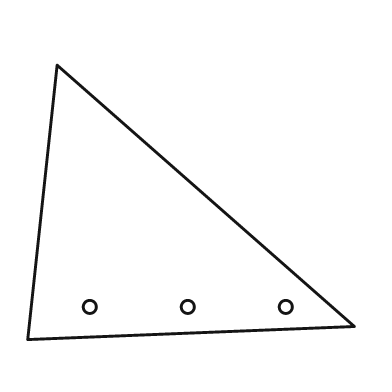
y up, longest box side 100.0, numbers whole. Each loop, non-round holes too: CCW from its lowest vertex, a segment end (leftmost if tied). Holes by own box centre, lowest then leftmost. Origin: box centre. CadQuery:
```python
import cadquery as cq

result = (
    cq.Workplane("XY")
    .moveTo(-50.0, -42.0)
    .lineTo(50.0, -38.0)
    .lineTo(-41.0, 42.0)
    .close()
    .moveTo(-31.0, -32.0)
    .circle(2.0)
    .moveTo(-1.0, -32.0)
    .circle(2.0)
    .moveTo(29.0, -32.0)
    .circle(2.0)
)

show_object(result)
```